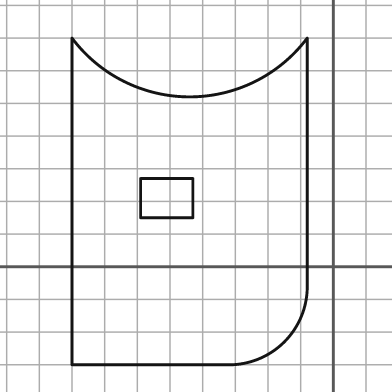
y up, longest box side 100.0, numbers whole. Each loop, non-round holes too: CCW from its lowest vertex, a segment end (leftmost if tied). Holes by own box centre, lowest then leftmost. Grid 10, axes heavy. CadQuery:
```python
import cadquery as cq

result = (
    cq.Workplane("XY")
    .moveTo(-80.0, -30.0)
    .lineTo(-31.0, -30.0)
    .threePointArc((-15.0, -23.0), (-8.0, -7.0))
    .lineTo(-8.0, 70.0)
    .threePointArc((-44.0, 52.0), (-80.0, 70.0))
    .close()
    .moveTo(-59.0, 15.0)
    .lineTo(-43.0, 15.0)
    .lineTo(-43.0, 27.0)
    .lineTo(-59.0, 27.0)
    .close()
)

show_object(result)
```